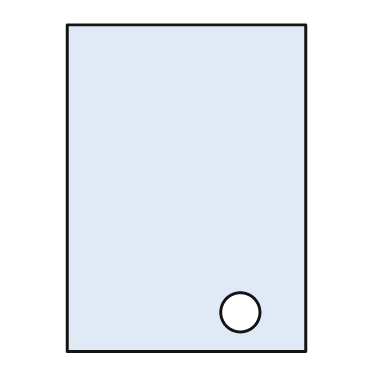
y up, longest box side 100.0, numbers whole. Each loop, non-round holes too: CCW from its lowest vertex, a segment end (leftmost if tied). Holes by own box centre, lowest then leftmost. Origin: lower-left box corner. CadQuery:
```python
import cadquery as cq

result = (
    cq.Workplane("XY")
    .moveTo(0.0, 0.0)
    .lineTo(73.0, 0.0)
    .lineTo(73.0, 100.0)
    .lineTo(0.0, 100.0)
    .close()
    .moveTo(53.0, 12.0)
    .circle(6.0)
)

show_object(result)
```